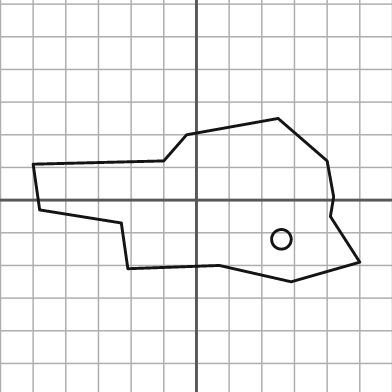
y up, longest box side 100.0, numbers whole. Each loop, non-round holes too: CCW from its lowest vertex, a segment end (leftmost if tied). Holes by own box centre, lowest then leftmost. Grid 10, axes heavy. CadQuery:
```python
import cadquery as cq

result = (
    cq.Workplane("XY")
    .moveTo(29.0, -25.0)
    .lineTo(50.0, -19.0)
    .lineTo(41.0, -5.0)
    .lineTo(42.0, 1.0)
    .lineTo(40.0, 12.0)
    .lineTo(25.0, 25.0)
    .lineTo(-3.0, 20.0)
    .lineTo(-10.0, 12.0)
    .lineTo(-50.0, 11.0)
    .lineTo(-48.0, -3.0)
    .lineTo(-23.0, -7.0)
    .lineTo(-21.0, -21.0)
    .lineTo(7.0, -20.0)
    .close()
    .moveTo(26.0, -12.0)
    .circle(3.0)
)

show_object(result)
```